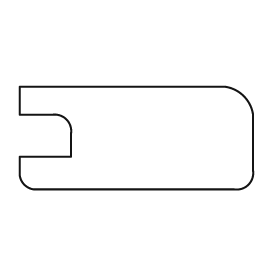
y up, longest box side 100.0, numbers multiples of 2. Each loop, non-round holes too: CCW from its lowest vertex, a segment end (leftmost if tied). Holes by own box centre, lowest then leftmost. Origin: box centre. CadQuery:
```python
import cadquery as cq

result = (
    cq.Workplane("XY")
    .moveTo(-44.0, -22.0)
    .lineTo(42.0, -22.0)
    .threePointArc((48.0, -20.0), (50.0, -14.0))
    .lineTo(50.0, 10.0)
    .threePointArc((46.0, 18.0), (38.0, 22.0))
    .lineTo(-50.0, 22.0)
    .lineTo(-50.0, 10.0)
    .lineTo(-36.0, 10.0)
    .threePointArc((-30.0, 8.0), (-28.0, 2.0))
    .lineTo(-28.0, -8.0)
    .lineTo(-50.0, -8.0)
    .lineTo(-50.0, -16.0)
    .threePointArc((-48.0, -20.0), (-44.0, -22.0))
    .close()
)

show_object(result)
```